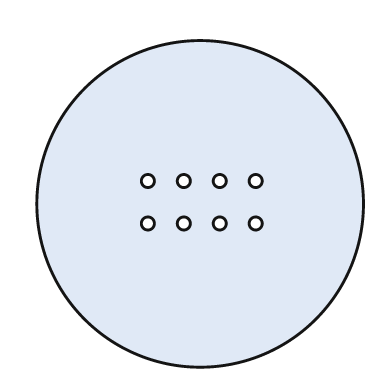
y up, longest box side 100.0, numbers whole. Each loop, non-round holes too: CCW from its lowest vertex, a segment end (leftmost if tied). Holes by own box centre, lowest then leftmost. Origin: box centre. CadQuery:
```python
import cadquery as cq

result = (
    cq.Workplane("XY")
    .moveTo(0.0, 0.0)
    .circle(50.0)
    .moveTo(-16.0, -6.0)
    .circle(2.0)
    .moveTo(-5.0, -6.0)
    .circle(2.0)
    .moveTo(6.0, -6.0)
    .circle(2.0)
    .moveTo(17.0, -6.0)
    .circle(2.0)
    .moveTo(-16.0, 7.0)
    .circle(2.0)
    .moveTo(-5.0, 7.0)
    .circle(2.0)
    .moveTo(6.0, 7.0)
    .circle(2.0)
    .moveTo(17.0, 7.0)
    .circle(2.0)
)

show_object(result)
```